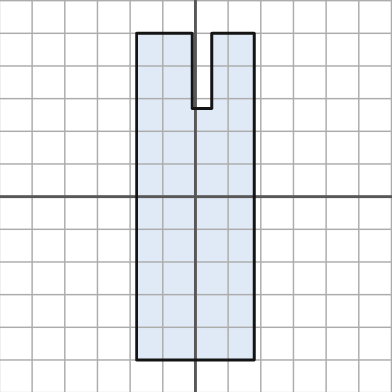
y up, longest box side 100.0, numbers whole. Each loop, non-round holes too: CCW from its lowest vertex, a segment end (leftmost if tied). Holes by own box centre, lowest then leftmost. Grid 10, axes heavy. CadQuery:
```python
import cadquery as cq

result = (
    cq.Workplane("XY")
    .moveTo(-18.0, -50.0)
    .lineTo(18.0, -50.0)
    .lineTo(18.0, 50.0)
    .lineTo(5.0, 50.0)
    .lineTo(5.0, 27.0)
    .lineTo(-1.0, 27.0)
    .lineTo(-1.0, 50.0)
    .lineTo(-18.0, 50.0)
    .close()
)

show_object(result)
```